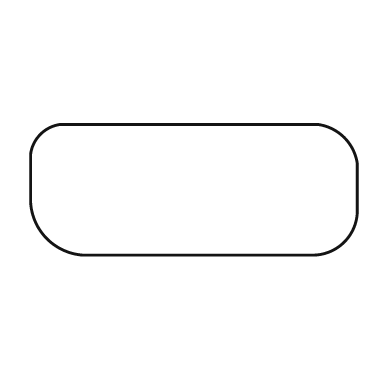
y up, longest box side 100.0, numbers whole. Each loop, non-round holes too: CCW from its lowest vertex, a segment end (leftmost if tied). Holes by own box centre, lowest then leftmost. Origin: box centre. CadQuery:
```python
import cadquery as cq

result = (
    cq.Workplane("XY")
    .moveTo(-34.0, -20.0)
    .lineTo(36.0, -20.0)
    .threePointArc((46.0, -16.0), (50.0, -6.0))
    .lineTo(50.0, 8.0)
    .threePointArc((46.0, 16.0), (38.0, 20.0))
    .lineTo(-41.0, 20.0)
    .threePointArc((-47.0, 17.0), (-50.0, 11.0))
    .lineTo(-50.0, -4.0)
    .threePointArc((-45.0, -15.0), (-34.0, -20.0))
    .close()
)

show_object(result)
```